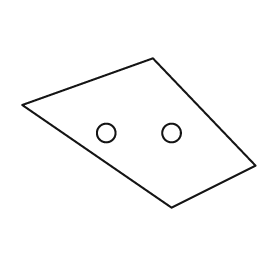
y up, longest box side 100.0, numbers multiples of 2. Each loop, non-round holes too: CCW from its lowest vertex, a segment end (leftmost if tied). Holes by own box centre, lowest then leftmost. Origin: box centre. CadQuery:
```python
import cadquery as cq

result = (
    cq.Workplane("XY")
    .moveTo(14.0, -32.0)
    .lineTo(50.0, -14.0)
    .lineTo(6.0, 32.0)
    .lineTo(-50.0, 12.0)
    .close()
    .moveTo(-14.0, 0.0)
    .circle(4.0)
    .moveTo(14.0, 0.0)
    .circle(4.0)
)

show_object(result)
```